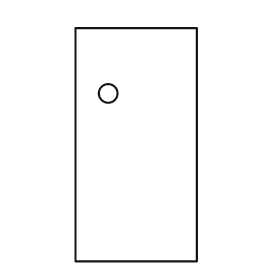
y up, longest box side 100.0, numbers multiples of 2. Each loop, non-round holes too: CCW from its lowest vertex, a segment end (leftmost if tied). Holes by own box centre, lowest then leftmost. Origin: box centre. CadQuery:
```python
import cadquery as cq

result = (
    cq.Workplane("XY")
    .moveTo(-26.0, -50.0)
    .lineTo(26.0, -50.0)
    .lineTo(26.0, 50.0)
    .lineTo(-26.0, 50.0)
    .close()
    .moveTo(-12.0, 22.0)
    .circle(4.0)
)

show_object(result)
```